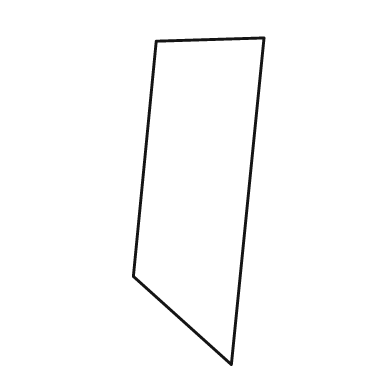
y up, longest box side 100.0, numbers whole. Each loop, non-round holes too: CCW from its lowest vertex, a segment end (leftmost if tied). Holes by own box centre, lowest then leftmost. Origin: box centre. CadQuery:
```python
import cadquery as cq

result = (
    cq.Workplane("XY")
    .moveTo(10.0, -50.0)
    .lineTo(20.0, 50.0)
    .lineTo(-13.0, 49.0)
    .lineTo(-20.0, -23.0)
    .close()
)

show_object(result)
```